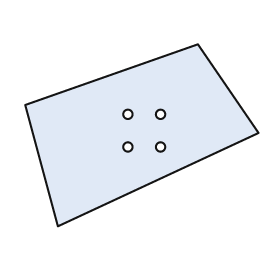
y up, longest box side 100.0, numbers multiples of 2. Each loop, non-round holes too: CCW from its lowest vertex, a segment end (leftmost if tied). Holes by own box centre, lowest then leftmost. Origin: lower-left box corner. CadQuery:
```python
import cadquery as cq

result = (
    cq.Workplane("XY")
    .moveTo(14.0, 0.0)
    .lineTo(100.0, 40.0)
    .lineTo(74.0, 78.0)
    .lineTo(0.0, 52.0)
    .close()
    .moveTo(44.0, 34.0)
    .circle(2.0)
    .moveTo(58.0, 34.0)
    .circle(2.0)
    .moveTo(44.0, 48.0)
    .circle(2.0)
    .moveTo(58.0, 48.0)
    .circle(2.0)
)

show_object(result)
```